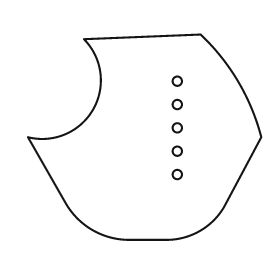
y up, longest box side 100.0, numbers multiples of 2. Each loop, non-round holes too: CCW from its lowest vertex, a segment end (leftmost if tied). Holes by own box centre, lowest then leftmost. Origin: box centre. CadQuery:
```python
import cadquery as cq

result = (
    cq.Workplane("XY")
    .moveTo(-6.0, -44.0)
    .lineTo(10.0, -44.0)
    .threePointArc((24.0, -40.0), (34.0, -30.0))
    .lineTo(50.0, 0.0)
    .threePointArc((40.0, 24.0), (24.0, 44.0))
    .lineTo(-26.0, 42.0)
    .threePointArc((-22.0, 12.0), (-50.0, 0.0))
    .lineTo(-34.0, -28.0)
    .threePointArc((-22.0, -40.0), (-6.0, -44.0))
    .close()
    .moveTo(14.0, -16.0)
    .circle(2.0)
    .moveTo(14.0, -6.0)
    .circle(2.0)
    .moveTo(14.0, 4.0)
    .circle(2.0)
    .moveTo(14.0, 14.0)
    .circle(2.0)
    .moveTo(14.0, 24.0)
    .circle(2.0)
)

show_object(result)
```